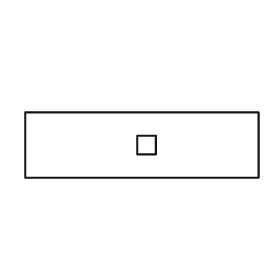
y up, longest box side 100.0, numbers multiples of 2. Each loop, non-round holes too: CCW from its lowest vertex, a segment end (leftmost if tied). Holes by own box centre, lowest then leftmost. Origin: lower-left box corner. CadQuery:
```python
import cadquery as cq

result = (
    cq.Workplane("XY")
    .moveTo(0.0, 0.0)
    .lineTo(100.0, 0.0)
    .lineTo(100.0, 28.0)
    .lineTo(0.0, 28.0)
    .close()
    .moveTo(48.0, 10.0)
    .lineTo(56.0, 10.0)
    .lineTo(56.0, 18.0)
    .lineTo(48.0, 18.0)
    .close()
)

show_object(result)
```